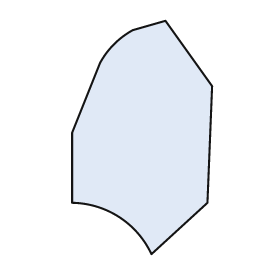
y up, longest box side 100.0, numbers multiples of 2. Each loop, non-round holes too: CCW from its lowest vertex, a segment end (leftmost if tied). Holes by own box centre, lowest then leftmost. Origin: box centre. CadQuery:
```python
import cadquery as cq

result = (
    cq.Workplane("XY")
    .moveTo(4.0, -50.0)
    .lineTo(28.0, -28.0)
    .lineTo(30.0, 22.0)
    .lineTo(10.0, 50.0)
    .lineTo(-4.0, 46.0)
    .threePointArc((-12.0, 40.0), (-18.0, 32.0))
    .lineTo(-30.0, 2.0)
    .lineTo(-30.0, -28.0)
    .threePointArc((-10.0, -34.0), (4.0, -50.0))
    .close()
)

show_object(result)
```